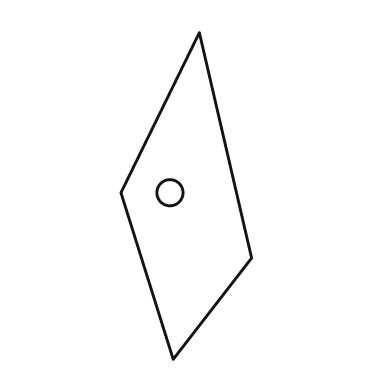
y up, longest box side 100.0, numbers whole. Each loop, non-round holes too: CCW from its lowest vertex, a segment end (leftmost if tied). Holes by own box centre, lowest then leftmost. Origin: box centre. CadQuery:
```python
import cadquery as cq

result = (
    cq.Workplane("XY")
    .moveTo(-4.0, -50.0)
    .lineTo(20.0, -19.0)
    .lineTo(4.0, 50.0)
    .lineTo(-20.0, 1.0)
    .close()
    .moveTo(-5.0, 1.0)
    .circle(4.0)
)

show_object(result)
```